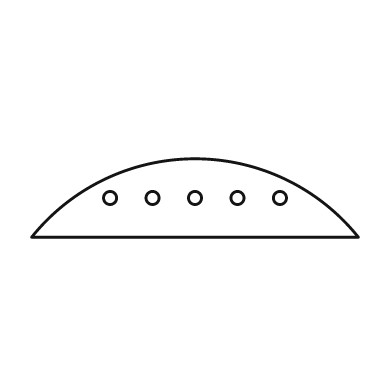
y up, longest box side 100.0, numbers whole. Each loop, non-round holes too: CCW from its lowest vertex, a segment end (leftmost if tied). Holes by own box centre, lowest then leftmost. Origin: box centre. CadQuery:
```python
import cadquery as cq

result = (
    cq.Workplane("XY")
    .moveTo(-50.0, -12.0)
    .lineTo(50.0, -12.0)
    .threePointArc((0.0, 12.0), (-50.0, -12.0))
    .close()
    .moveTo(-26.0, 0.0)
    .circle(2.0)
    .moveTo(-13.0, 0.0)
    .circle(2.0)
    .moveTo(0.0, 0.0)
    .circle(2.0)
    .moveTo(13.0, 0.0)
    .circle(2.0)
    .moveTo(26.0, 0.0)
    .circle(2.0)
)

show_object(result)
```